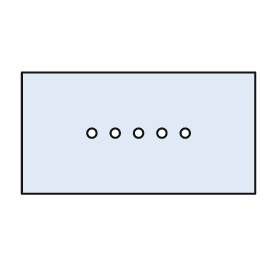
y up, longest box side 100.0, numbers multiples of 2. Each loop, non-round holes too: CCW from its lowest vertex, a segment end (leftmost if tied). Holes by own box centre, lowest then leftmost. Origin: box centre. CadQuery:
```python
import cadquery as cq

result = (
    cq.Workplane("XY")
    .moveTo(-50.0, -26.0)
    .lineTo(50.0, -26.0)
    .lineTo(50.0, 26.0)
    .lineTo(-50.0, 26.0)
    .close()
    .moveTo(-20.0, 0.0)
    .circle(2.0)
    .moveTo(-10.0, 0.0)
    .circle(2.0)
    .moveTo(0.0, 0.0)
    .circle(2.0)
    .moveTo(10.0, 0.0)
    .circle(2.0)
    .moveTo(20.0, 0.0)
    .circle(2.0)
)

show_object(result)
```